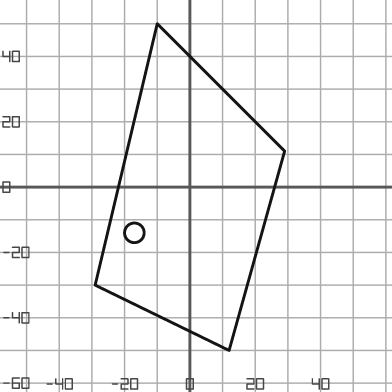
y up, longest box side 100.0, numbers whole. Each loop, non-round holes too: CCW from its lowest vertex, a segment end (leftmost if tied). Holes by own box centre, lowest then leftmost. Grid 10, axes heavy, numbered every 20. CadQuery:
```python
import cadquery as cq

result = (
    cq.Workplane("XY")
    .moveTo(12.0, -50.0)
    .lineTo(29.0, 11.0)
    .lineTo(-10.0, 50.0)
    .lineTo(-29.0, -30.0)
    .close()
    .moveTo(-17.0, -14.0)
    .circle(3.0)
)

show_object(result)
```